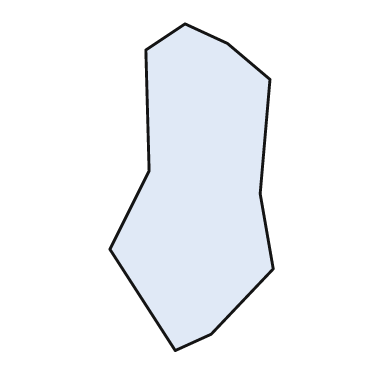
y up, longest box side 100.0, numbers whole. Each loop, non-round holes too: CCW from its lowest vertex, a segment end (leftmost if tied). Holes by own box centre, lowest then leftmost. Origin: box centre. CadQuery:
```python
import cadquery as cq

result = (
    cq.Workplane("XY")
    .moveTo(-5.0, -50.0)
    .lineTo(6.0, -45.0)
    .lineTo(25.0, -25.0)
    .lineTo(21.0, -2.0)
    .lineTo(24.0, 33.0)
    .lineTo(11.0, 44.0)
    .lineTo(-2.0, 50.0)
    .lineTo(-14.0, 42.0)
    .lineTo(-13.0, 5.0)
    .lineTo(-25.0, -19.0)
    .close()
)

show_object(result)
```